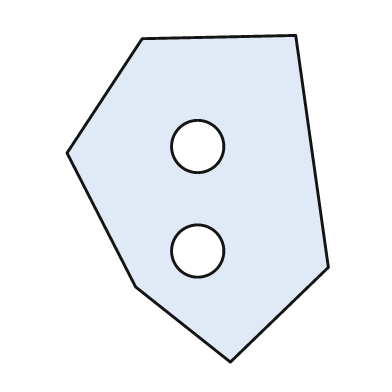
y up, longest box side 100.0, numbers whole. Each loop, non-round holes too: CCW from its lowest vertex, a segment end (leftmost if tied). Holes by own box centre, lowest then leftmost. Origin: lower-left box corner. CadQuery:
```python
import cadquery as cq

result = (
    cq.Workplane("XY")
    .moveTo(50.0, 0.0)
    .lineTo(80.0, 29.0)
    .lineTo(70.0, 100.0)
    .lineTo(23.0, 99.0)
    .lineTo(0.0, 64.0)
    .lineTo(21.0, 23.0)
    .close()
    .moveTo(40.0, 34.0)
    .circle(8.0)
    .moveTo(40.0, 66.0)
    .circle(8.0)
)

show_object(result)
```